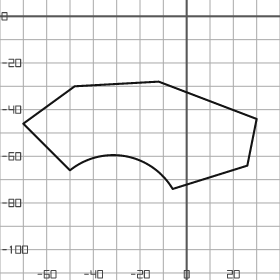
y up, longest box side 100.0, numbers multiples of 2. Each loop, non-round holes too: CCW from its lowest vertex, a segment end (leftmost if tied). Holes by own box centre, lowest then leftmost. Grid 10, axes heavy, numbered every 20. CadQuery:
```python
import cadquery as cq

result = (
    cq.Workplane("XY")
    .moveTo(-6.0, -74.0)
    .lineTo(26.0, -64.0)
    .lineTo(30.0, -44.0)
    .lineTo(-12.0, -28.0)
    .lineTo(-48.0, -30.0)
    .lineTo(-70.0, -46.0)
    .lineTo(-50.0, -66.0)
    .threePointArc((-26.0, -60.0), (-6.0, -74.0))
    .close()
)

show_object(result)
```